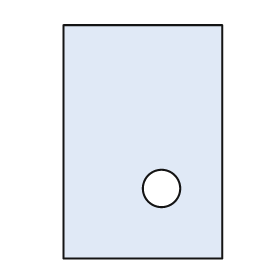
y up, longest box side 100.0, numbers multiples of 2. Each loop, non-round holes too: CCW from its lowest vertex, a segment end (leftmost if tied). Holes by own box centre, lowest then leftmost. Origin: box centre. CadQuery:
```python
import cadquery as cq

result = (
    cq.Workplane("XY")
    .moveTo(-34.0, -50.0)
    .lineTo(34.0, -50.0)
    .lineTo(34.0, 50.0)
    .lineTo(-34.0, 50.0)
    .close()
    .moveTo(8.0, -20.0)
    .circle(8.0)
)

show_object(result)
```